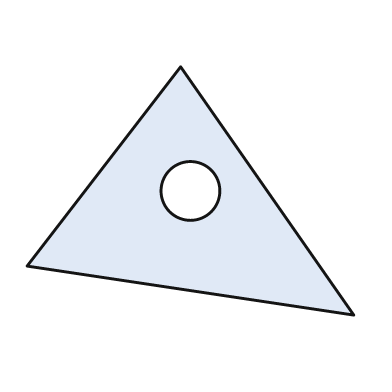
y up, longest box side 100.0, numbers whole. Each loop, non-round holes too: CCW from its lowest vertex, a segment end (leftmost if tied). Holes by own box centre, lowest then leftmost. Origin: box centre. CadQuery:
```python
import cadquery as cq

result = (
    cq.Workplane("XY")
    .moveTo(50.0, -38.0)
    .lineTo(-3.0, 38.0)
    .lineTo(-50.0, -23.0)
    .close()
    .moveTo(0.0, 0.0)
    .circle(9.0)
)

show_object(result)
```